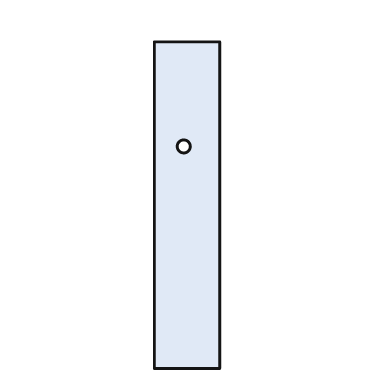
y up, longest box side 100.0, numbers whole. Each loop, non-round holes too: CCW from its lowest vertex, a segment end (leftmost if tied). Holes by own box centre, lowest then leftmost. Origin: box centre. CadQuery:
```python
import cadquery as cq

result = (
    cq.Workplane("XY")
    .moveTo(-10.0, -50.0)
    .lineTo(10.0, -50.0)
    .lineTo(10.0, 50.0)
    .lineTo(-10.0, 50.0)
    .close()
    .moveTo(-1.0, 18.0)
    .circle(2.0)
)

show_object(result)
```